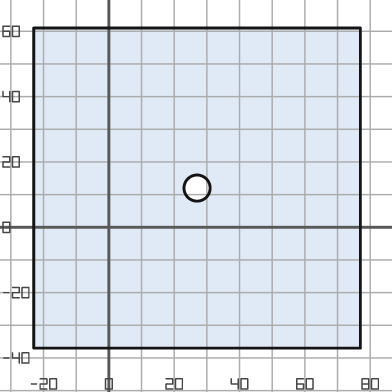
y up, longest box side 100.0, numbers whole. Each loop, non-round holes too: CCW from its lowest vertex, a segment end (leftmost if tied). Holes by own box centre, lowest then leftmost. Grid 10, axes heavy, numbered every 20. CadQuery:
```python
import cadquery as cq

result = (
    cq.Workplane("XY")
    .moveTo(-23.0, -37.0)
    .lineTo(77.0, -37.0)
    .lineTo(77.0, 61.0)
    .lineTo(-23.0, 61.0)
    .close()
    .moveTo(27.0, 12.0)
    .circle(4.0)
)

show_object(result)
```